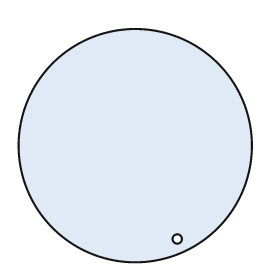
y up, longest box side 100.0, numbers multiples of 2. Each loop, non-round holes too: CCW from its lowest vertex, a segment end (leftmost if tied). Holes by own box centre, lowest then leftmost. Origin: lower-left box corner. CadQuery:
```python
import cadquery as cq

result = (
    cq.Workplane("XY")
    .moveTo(50.0, 50.0)
    .circle(50.0)
    .moveTo(68.0, 10.0)
    .circle(2.0)
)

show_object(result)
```